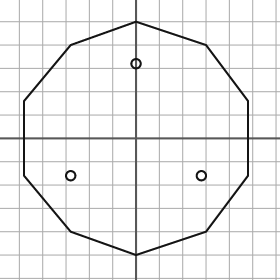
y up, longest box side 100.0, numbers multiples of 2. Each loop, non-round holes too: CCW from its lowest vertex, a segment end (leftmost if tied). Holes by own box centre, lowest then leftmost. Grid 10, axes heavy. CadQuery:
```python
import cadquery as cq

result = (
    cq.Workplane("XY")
    .moveTo(0.0, -50.0)
    .lineTo(30.0, -40.0)
    .lineTo(48.0, -16.0)
    .lineTo(48.0, 16.0)
    .lineTo(30.0, 40.0)
    .lineTo(0.0, 50.0)
    .lineTo(-28.0, 40.0)
    .lineTo(-48.0, 16.0)
    .lineTo(-48.0, -16.0)
    .lineTo(-28.0, -40.0)
    .close()
    .moveTo(-28.0, -16.0)
    .circle(2.0)
    .moveTo(28.0, -16.0)
    .circle(2.0)
    .moveTo(0.0, 32.0)
    .circle(2.0)
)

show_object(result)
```